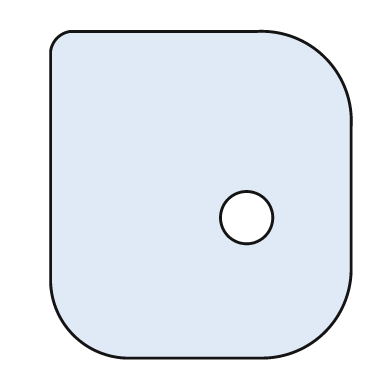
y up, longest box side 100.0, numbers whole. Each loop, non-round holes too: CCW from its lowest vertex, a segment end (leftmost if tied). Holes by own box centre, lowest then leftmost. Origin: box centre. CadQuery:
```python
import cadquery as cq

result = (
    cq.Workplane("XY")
    .moveTo(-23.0, -50.0)
    .lineTo(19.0, -50.0)
    .threePointArc((38.0, -42.0), (46.0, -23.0))
    .lineTo(46.0, 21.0)
    .threePointArc((38.0, 42.0), (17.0, 50.0))
    .lineTo(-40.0, 50.0)
    .threePointArc((-44.0, 48.0), (-46.0, 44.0))
    .lineTo(-46.0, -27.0)
    .threePointArc((-39.0, -43.0), (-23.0, -50.0))
    .close()
    .moveTo(14.0, -7.0)
    .circle(8.0)
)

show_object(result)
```